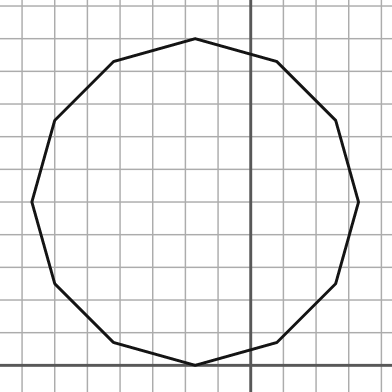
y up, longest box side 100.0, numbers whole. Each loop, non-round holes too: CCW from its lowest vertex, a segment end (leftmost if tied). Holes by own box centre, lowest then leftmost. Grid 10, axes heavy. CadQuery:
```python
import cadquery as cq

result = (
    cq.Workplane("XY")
    .moveTo(-17.0, 0.0)
    .lineTo(8.0, 7.0)
    .lineTo(26.0, 25.0)
    .lineTo(33.0, 50.0)
    .lineTo(26.0, 75.0)
    .lineTo(8.0, 93.0)
    .lineTo(-17.0, 100.0)
    .lineTo(-42.0, 93.0)
    .lineTo(-60.0, 75.0)
    .lineTo(-67.0, 50.0)
    .lineTo(-60.0, 25.0)
    .lineTo(-42.0, 7.0)
    .close()
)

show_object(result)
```